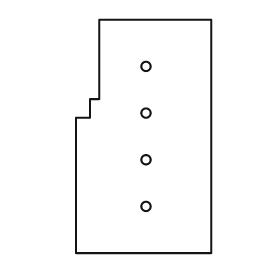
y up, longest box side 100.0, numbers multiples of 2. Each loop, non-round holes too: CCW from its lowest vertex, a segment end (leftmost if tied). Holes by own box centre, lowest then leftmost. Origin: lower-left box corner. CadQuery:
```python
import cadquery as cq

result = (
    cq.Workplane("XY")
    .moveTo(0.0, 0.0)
    .lineTo(58.0, 0.0)
    .lineTo(58.0, 100.0)
    .lineTo(10.0, 100.0)
    .lineTo(10.0, 66.0)
    .lineTo(6.0, 66.0)
    .lineTo(6.0, 58.0)
    .lineTo(0.0, 58.0)
    .close()
    .moveTo(30.0, 20.0)
    .circle(2.0)
    .moveTo(30.0, 40.0)
    .circle(2.0)
    .moveTo(30.0, 60.0)
    .circle(2.0)
    .moveTo(30.0, 80.0)
    .circle(2.0)
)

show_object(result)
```